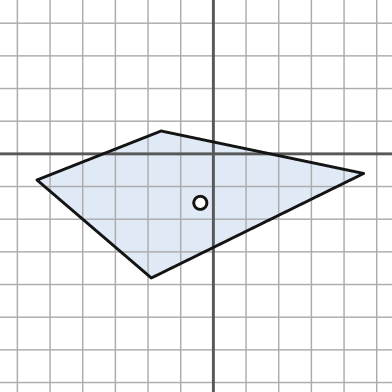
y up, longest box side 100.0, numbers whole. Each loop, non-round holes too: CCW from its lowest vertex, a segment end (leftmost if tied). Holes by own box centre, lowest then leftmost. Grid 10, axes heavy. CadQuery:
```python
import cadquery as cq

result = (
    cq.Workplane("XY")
    .moveTo(-19.0, -38.0)
    .lineTo(46.0, -6.0)
    .lineTo(-16.0, 7.0)
    .lineTo(-54.0, -8.0)
    .close()
    .moveTo(-4.0, -15.0)
    .circle(2.0)
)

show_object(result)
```